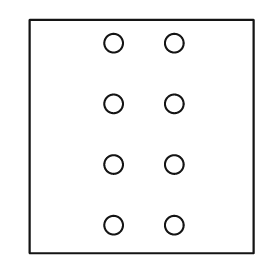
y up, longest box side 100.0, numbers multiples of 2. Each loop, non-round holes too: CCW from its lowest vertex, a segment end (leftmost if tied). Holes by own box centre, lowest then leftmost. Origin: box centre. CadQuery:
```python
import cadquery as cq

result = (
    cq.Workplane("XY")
    .moveTo(-48.0, -50.0)
    .lineTo(48.0, -50.0)
    .lineTo(48.0, 50.0)
    .lineTo(-48.0, 50.0)
    .close()
    .moveTo(-12.0, -38.0)
    .circle(4.0)
    .moveTo(14.0, -38.0)
    .circle(4.0)
    .moveTo(-12.0, -12.0)
    .circle(4.0)
    .moveTo(14.0, -12.0)
    .circle(4.0)
    .moveTo(-12.0, 14.0)
    .circle(4.0)
    .moveTo(14.0, 14.0)
    .circle(4.0)
    .moveTo(-12.0, 40.0)
    .circle(4.0)
    .moveTo(14.0, 40.0)
    .circle(4.0)
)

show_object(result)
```